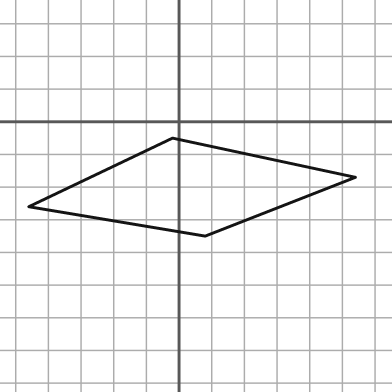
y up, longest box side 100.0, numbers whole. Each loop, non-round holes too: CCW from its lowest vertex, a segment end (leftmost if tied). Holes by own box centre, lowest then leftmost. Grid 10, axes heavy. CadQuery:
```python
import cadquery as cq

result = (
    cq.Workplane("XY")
    .moveTo(8.0, -35.0)
    .lineTo(54.0, -17.0)
    .lineTo(-2.0, -5.0)
    .lineTo(-46.0, -26.0)
    .close()
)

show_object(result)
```